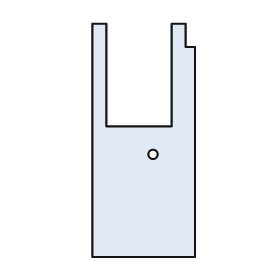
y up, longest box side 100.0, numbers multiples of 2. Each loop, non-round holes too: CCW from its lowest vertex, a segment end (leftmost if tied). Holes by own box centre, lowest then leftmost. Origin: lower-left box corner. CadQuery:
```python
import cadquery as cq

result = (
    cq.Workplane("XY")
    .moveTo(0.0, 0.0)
    .lineTo(44.0, 0.0)
    .lineTo(44.0, 90.0)
    .lineTo(40.0, 90.0)
    .lineTo(40.0, 100.0)
    .lineTo(34.0, 100.0)
    .lineTo(34.0, 56.0)
    .lineTo(6.0, 56.0)
    .lineTo(6.0, 100.0)
    .lineTo(0.0, 100.0)
    .close()
    .moveTo(26.0, 44.0)
    .circle(2.0)
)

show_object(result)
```